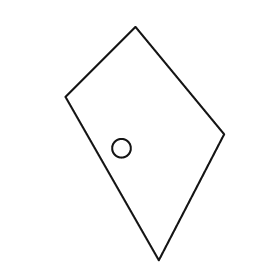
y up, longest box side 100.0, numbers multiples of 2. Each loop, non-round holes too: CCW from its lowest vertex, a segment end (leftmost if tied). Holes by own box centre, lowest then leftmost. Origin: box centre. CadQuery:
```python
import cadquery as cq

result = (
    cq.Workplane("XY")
    .moveTo(6.0, -50.0)
    .lineTo(34.0, 4.0)
    .lineTo(-4.0, 50.0)
    .lineTo(-34.0, 20.0)
    .close()
    .moveTo(-10.0, -2.0)
    .circle(4.0)
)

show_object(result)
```